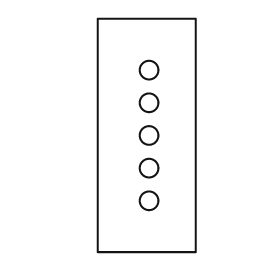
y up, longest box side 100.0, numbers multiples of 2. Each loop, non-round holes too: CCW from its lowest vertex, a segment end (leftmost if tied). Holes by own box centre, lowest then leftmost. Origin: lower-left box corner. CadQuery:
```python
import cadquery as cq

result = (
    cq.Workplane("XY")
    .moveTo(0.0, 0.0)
    .lineTo(42.0, 0.0)
    .lineTo(42.0, 100.0)
    .lineTo(0.0, 100.0)
    .close()
    .moveTo(22.0, 22.0)
    .circle(4.0)
    .moveTo(22.0, 36.0)
    .circle(4.0)
    .moveTo(22.0, 50.0)
    .circle(4.0)
    .moveTo(22.0, 64.0)
    .circle(4.0)
    .moveTo(22.0, 78.0)
    .circle(4.0)
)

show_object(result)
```